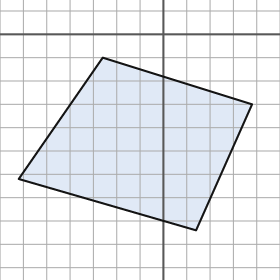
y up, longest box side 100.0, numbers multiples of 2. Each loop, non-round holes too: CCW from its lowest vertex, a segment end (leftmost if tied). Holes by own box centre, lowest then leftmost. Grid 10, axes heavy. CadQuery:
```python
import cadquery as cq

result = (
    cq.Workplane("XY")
    .moveTo(14.0, -84.0)
    .lineTo(38.0, -30.0)
    .lineTo(-26.0, -10.0)
    .lineTo(-62.0, -62.0)
    .close()
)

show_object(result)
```